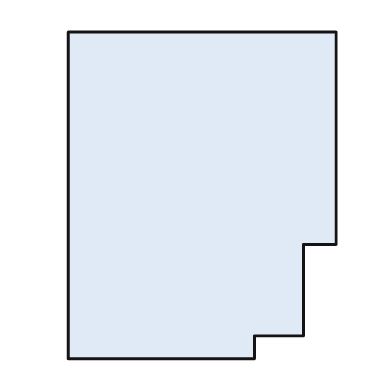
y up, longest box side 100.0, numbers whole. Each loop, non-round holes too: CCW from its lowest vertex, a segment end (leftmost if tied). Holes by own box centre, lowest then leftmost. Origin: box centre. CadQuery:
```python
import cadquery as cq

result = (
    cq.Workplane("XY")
    .moveTo(-41.0, -50.0)
    .lineTo(16.0, -50.0)
    .lineTo(16.0, -43.0)
    .lineTo(31.0, -43.0)
    .lineTo(31.0, -15.0)
    .lineTo(41.0, -15.0)
    .lineTo(41.0, 50.0)
    .lineTo(-41.0, 50.0)
    .close()
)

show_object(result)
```